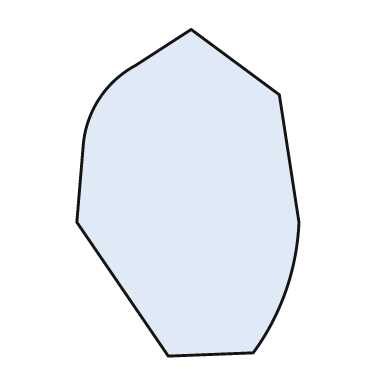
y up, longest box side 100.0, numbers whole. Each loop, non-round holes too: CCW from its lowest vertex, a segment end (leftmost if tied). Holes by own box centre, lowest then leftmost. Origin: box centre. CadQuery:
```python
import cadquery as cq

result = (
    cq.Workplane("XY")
    .moveTo(-6.0, -50.0)
    .lineTo(20.0, -49.0)
    .threePointArc((30.0, -30.0), (34.0, -9.0))
    .lineTo(28.0, 30.0)
    .lineTo(1.0, 50.0)
    .lineTo(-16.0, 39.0)
    .threePointArc((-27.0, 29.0), (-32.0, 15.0))
    .lineTo(-34.0, -9.0)
    .close()
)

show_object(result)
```